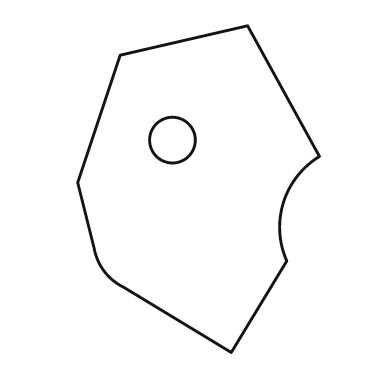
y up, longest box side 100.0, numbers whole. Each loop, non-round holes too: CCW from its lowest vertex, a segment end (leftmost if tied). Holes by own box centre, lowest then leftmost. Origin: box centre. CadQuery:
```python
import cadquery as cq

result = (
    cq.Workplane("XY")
    .moveTo(10.0, -50.0)
    .lineTo(27.0, -22.0)
    .threePointArc((26.0, -4.0), (37.0, 10.0))
    .lineTo(15.0, 50.0)
    .lineTo(-24.0, 41.0)
    .lineTo(-37.0, 2.0)
    .lineTo(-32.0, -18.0)
    .threePointArc((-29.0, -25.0), (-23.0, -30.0))
    .close()
    .moveTo(-8.0, 15.0)
    .circle(7.0)
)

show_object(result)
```